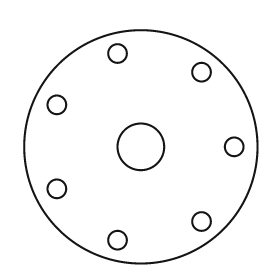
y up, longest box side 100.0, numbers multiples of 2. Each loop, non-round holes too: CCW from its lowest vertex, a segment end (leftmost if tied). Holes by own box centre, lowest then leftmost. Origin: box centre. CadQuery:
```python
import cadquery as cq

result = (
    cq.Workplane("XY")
    .moveTo(0.0, 0.0)
    .circle(50.0)
    .moveTo(-10.0, -40.0)
    .circle(4.0)
    .moveTo(26.0, -32.0)
    .circle(4.0)
    .moveTo(-36.0, -18.0)
    .circle(4.0)
    .moveTo(0.0, 0.0)
    .circle(10.0)
    .moveTo(40.0, 0.0)
    .circle(4.0)
    .moveTo(-36.0, 18.0)
    .circle(4.0)
    .moveTo(26.0, 32.0)
    .circle(4.0)
    .moveTo(-10.0, 40.0)
    .circle(4.0)
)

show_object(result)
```